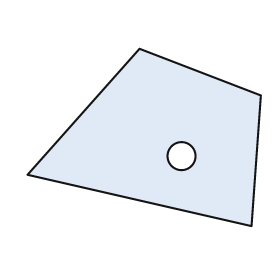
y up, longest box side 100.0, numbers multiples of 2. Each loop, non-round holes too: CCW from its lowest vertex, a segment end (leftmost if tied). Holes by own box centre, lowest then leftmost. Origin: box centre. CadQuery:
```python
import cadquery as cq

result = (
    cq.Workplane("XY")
    .moveTo(46.0, -38.0)
    .lineTo(50.0, 18.0)
    .lineTo(-2.0, 38.0)
    .lineTo(-50.0, -16.0)
    .close()
    .moveTo(16.0, -8.0)
    .circle(6.0)
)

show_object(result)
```